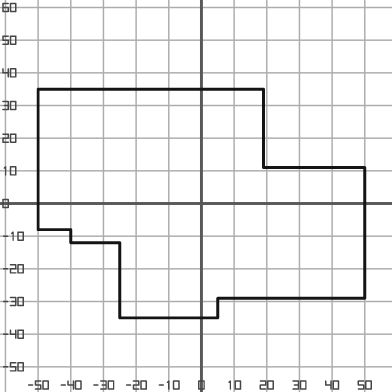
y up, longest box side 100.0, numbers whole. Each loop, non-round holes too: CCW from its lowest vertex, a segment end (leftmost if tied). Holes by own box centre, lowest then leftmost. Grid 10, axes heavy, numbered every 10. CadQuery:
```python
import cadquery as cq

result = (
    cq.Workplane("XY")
    .moveTo(-25.0, -35.0)
    .lineTo(5.0, -35.0)
    .lineTo(5.0, -29.0)
    .lineTo(50.0, -29.0)
    .lineTo(50.0, 11.0)
    .lineTo(19.0, 11.0)
    .lineTo(19.0, 35.0)
    .lineTo(-50.0, 35.0)
    .lineTo(-50.0, -8.0)
    .lineTo(-40.0, -8.0)
    .lineTo(-40.0, -12.0)
    .lineTo(-25.0, -12.0)
    .close()
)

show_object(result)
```